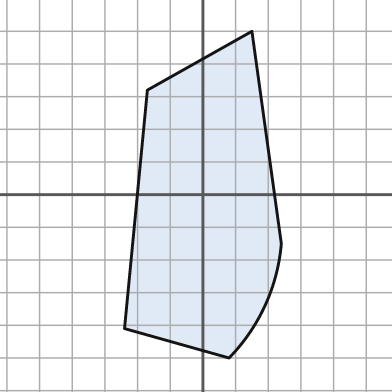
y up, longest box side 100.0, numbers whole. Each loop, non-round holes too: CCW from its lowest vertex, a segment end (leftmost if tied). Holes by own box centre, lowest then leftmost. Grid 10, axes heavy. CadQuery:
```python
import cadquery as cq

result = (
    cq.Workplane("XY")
    .moveTo(8.0, -50.0)
    .threePointArc((19.0, -34.0), (24.0, -15.0))
    .lineTo(15.0, 50.0)
    .lineTo(-17.0, 32.0)
    .lineTo(-24.0, -41.0)
    .close()
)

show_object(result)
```